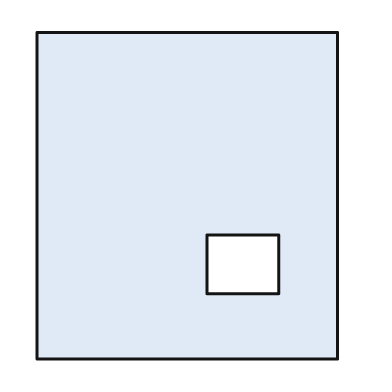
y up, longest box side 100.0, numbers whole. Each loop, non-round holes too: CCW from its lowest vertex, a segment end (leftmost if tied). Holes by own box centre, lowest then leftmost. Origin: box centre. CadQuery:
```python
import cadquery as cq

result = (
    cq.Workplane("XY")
    .moveTo(-46.0, -50.0)
    .lineTo(46.0, -50.0)
    .lineTo(46.0, 50.0)
    .lineTo(-46.0, 50.0)
    .close()
    .moveTo(6.0, -30.0)
    .lineTo(28.0, -30.0)
    .lineTo(28.0, -12.0)
    .lineTo(6.0, -12.0)
    .close()
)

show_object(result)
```